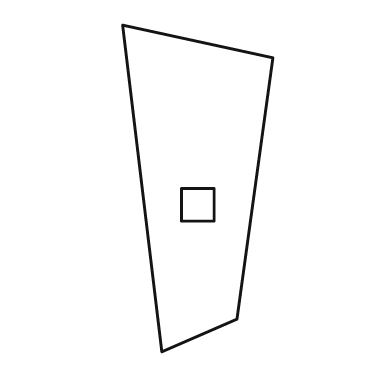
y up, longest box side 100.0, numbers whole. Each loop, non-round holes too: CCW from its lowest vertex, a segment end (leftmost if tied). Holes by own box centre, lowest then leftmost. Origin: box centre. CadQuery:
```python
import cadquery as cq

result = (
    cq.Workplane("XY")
    .moveTo(-11.0, -50.0)
    .lineTo(12.0, -40.0)
    .lineTo(23.0, 40.0)
    .lineTo(-23.0, 50.0)
    .close()
    .moveTo(-5.0, -10.0)
    .lineTo(5.0, -10.0)
    .lineTo(5.0, 0.0)
    .lineTo(-5.0, 0.0)
    .close()
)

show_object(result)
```